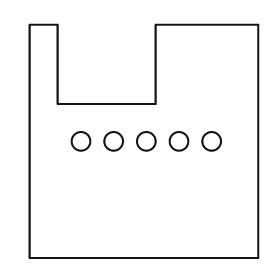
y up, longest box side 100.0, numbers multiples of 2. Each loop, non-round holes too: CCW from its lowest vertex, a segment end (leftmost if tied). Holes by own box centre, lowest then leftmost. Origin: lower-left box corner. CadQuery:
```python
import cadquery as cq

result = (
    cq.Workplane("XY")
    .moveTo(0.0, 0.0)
    .lineTo(98.0, 0.0)
    .lineTo(98.0, 100.0)
    .lineTo(54.0, 100.0)
    .lineTo(54.0, 66.0)
    .lineTo(12.0, 66.0)
    .lineTo(12.0, 100.0)
    .lineTo(0.0, 100.0)
    .close()
    .moveTo(22.0, 50.0)
    .circle(4.0)
    .moveTo(36.0, 50.0)
    .circle(4.0)
    .moveTo(50.0, 50.0)
    .circle(4.0)
    .moveTo(64.0, 50.0)
    .circle(4.0)
    .moveTo(78.0, 50.0)
    .circle(4.0)
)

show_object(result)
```